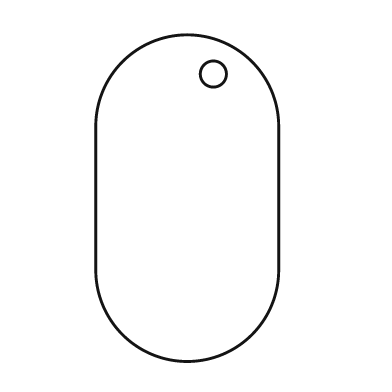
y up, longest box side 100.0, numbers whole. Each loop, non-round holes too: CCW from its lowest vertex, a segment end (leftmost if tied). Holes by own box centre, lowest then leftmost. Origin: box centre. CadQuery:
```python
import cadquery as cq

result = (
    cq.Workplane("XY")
    .moveTo(-28.0, -22.0)
    .threePointArc((0.0, -50.0), (28.0, -22.0))
    .lineTo(28.0, 22.0)
    .threePointArc((0.0, 50.0), (-28.0, 22.0))
    .close()
    .moveTo(8.0, 38.0)
    .circle(4.0)
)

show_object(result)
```